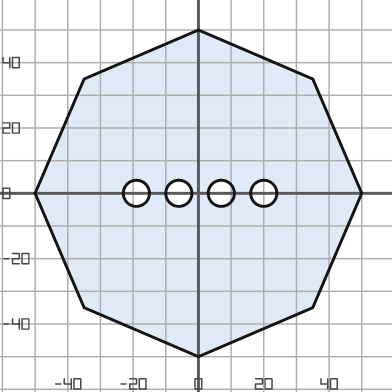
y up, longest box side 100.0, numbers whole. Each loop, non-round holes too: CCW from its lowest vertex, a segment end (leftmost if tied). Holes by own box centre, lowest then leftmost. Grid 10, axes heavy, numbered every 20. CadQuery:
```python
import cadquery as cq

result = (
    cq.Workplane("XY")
    .moveTo(0.0, -50.0)
    .lineTo(35.0, -35.0)
    .lineTo(50.0, 0.0)
    .lineTo(35.0, 35.0)
    .lineTo(0.0, 50.0)
    .lineTo(-35.0, 35.0)
    .lineTo(-50.0, 0.0)
    .lineTo(-35.0, -35.0)
    .close()
    .moveTo(-19.0, 0.0)
    .circle(4.0)
    .moveTo(-6.0, 0.0)
    .circle(4.0)
    .moveTo(7.0, 0.0)
    .circle(4.0)
    .moveTo(20.0, 0.0)
    .circle(4.0)
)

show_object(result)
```